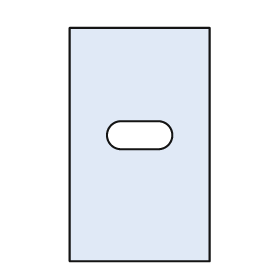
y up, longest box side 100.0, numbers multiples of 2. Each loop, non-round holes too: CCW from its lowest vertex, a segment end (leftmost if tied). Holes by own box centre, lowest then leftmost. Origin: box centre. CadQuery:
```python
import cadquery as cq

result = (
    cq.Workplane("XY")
    .moveTo(-30.0, -50.0)
    .lineTo(30.0, -50.0)
    .lineTo(30.0, 50.0)
    .lineTo(-30.0, 50.0)
    .close()
    .moveTo(-8.0, -2.0)
    .lineTo(8.0, -2.0)
    .threePointArc((14.0, 4.0), (8.0, 10.0))
    .lineTo(-8.0, 10.0)
    .threePointArc((-14.0, 4.0), (-8.0, -2.0))
    .close()
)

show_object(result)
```